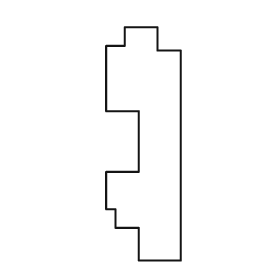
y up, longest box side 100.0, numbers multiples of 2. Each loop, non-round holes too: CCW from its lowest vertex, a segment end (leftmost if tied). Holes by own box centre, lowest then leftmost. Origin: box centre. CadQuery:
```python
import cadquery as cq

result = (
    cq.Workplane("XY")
    .moveTo(-2.0, -50.0)
    .lineTo(16.0, -50.0)
    .lineTo(16.0, 40.0)
    .lineTo(6.0, 40.0)
    .lineTo(6.0, 50.0)
    .lineTo(-8.0, 50.0)
    .lineTo(-8.0, 42.0)
    .lineTo(-16.0, 42.0)
    .lineTo(-16.0, 14.0)
    .lineTo(-2.0, 14.0)
    .lineTo(-2.0, -12.0)
    .lineTo(-16.0, -12.0)
    .lineTo(-16.0, -28.0)
    .lineTo(-12.0, -28.0)
    .lineTo(-12.0, -36.0)
    .lineTo(-2.0, -36.0)
    .close()
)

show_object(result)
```